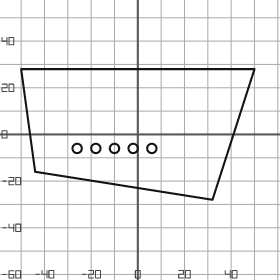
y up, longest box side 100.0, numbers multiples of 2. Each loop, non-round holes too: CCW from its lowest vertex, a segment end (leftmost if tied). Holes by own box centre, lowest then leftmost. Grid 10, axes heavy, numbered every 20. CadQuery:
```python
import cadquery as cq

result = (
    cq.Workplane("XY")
    .moveTo(32.0, -28.0)
    .lineTo(50.0, 28.0)
    .lineTo(-50.0, 28.0)
    .lineTo(-44.0, -16.0)
    .close()
    .moveTo(-26.0, -6.0)
    .circle(2.0)
    .moveTo(-18.0, -6.0)
    .circle(2.0)
    .moveTo(-10.0, -6.0)
    .circle(2.0)
    .moveTo(-2.0, -6.0)
    .circle(2.0)
    .moveTo(6.0, -6.0)
    .circle(2.0)
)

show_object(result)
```